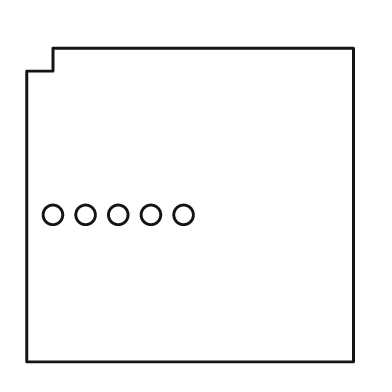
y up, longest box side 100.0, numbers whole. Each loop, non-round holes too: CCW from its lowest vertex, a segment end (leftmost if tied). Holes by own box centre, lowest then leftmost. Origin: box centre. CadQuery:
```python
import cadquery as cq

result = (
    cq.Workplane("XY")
    .moveTo(-50.0, -48.0)
    .lineTo(50.0, -48.0)
    .lineTo(50.0, 48.0)
    .lineTo(-42.0, 48.0)
    .lineTo(-42.0, 41.0)
    .lineTo(-50.0, 41.0)
    .close()
    .moveTo(-42.0, -3.0)
    .circle(3.0)
    .moveTo(-32.0, -3.0)
    .circle(3.0)
    .moveTo(-22.0, -3.0)
    .circle(3.0)
    .moveTo(-12.0, -3.0)
    .circle(3.0)
    .moveTo(-2.0, -3.0)
    .circle(3.0)
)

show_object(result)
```